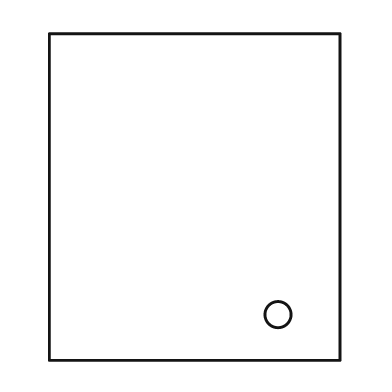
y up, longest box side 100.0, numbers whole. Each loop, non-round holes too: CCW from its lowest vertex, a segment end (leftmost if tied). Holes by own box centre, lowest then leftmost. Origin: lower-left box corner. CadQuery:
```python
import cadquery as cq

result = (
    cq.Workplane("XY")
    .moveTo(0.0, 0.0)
    .lineTo(89.0, 0.0)
    .lineTo(89.0, 100.0)
    .lineTo(0.0, 100.0)
    .close()
    .moveTo(70.0, 14.0)
    .circle(4.0)
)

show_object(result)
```